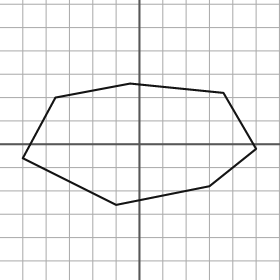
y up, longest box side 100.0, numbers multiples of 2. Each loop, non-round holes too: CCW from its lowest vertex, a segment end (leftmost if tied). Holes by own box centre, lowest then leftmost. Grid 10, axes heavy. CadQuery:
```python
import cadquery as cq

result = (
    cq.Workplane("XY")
    .moveTo(-10.0, -26.0)
    .lineTo(30.0, -18.0)
    .lineTo(50.0, -2.0)
    .lineTo(36.0, 22.0)
    .lineTo(-4.0, 26.0)
    .lineTo(-36.0, 20.0)
    .lineTo(-50.0, -6.0)
    .close()
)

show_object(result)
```